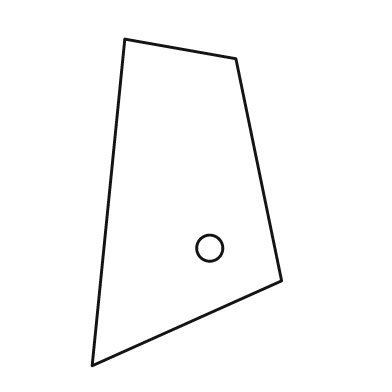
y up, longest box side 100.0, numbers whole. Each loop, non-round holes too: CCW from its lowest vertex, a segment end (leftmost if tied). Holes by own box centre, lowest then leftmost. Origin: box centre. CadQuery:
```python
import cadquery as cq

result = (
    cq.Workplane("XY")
    .moveTo(-29.0, -50.0)
    .lineTo(29.0, -24.0)
    .lineTo(15.0, 44.0)
    .lineTo(-19.0, 50.0)
    .close()
    .moveTo(7.0, -14.0)
    .circle(4.0)
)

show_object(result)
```